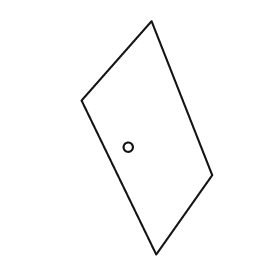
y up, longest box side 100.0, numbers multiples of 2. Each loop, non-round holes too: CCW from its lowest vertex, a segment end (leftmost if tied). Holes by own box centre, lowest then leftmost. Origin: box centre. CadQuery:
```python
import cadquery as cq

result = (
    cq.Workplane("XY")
    .moveTo(4.0, -50.0)
    .lineTo(28.0, -16.0)
    .lineTo(2.0, 50.0)
    .lineTo(-28.0, 16.0)
    .close()
    .moveTo(-8.0, -4.0)
    .circle(2.0)
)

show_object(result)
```